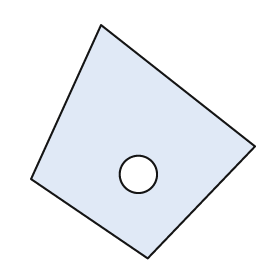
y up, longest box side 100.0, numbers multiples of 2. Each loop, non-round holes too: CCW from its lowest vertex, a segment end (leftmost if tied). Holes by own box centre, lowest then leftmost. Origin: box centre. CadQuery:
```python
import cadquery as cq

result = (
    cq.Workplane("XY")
    .moveTo(2.0, -50.0)
    .lineTo(48.0, -2.0)
    .lineTo(-18.0, 50.0)
    .lineTo(-48.0, -16.0)
    .close()
    .moveTo(-2.0, -14.0)
    .circle(8.0)
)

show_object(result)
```